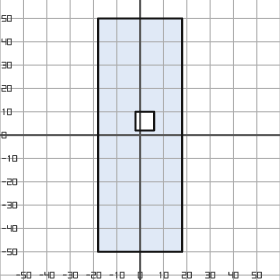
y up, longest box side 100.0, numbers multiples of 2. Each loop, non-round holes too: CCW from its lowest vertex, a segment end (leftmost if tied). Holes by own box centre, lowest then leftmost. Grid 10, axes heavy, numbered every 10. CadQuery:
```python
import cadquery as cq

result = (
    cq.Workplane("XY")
    .moveTo(-18.0, -50.0)
    .lineTo(18.0, -50.0)
    .lineTo(18.0, 50.0)
    .lineTo(-18.0, 50.0)
    .close()
    .moveTo(-2.0, 2.0)
    .lineTo(6.0, 2.0)
    .lineTo(6.0, 10.0)
    .lineTo(-2.0, 10.0)
    .close()
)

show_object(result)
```